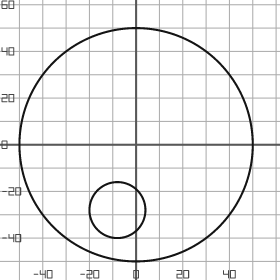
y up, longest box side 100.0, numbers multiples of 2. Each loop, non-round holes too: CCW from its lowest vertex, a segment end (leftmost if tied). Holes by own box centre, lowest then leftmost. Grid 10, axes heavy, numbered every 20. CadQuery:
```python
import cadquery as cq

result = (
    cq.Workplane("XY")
    .moveTo(0.0, 0.0)
    .circle(50.0)
    .moveTo(-8.0, -28.0)
    .circle(12.0)
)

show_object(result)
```